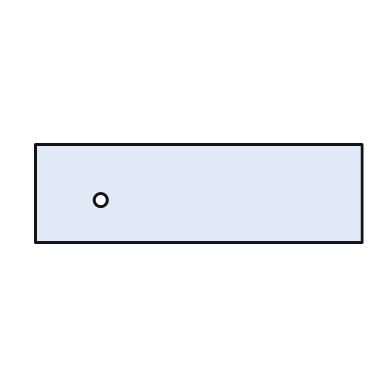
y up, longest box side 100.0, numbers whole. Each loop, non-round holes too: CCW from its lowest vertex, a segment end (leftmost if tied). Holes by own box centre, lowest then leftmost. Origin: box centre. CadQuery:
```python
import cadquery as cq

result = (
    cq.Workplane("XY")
    .moveTo(-50.0, -15.0)
    .lineTo(50.0, -15.0)
    .lineTo(50.0, 15.0)
    .lineTo(-50.0, 15.0)
    .close()
    .moveTo(-30.0, -2.0)
    .circle(2.0)
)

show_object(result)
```